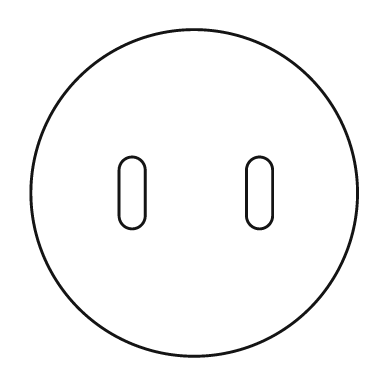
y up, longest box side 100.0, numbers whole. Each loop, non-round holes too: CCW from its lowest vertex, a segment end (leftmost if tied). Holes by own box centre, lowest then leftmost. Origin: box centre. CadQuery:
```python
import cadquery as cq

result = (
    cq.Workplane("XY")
    .moveTo(0.0, 0.0)
    .circle(50.0)
    .moveTo(-23.0, -7.0)
    .threePointArc((-19.0, -11.0), (-15.0, -7.0))
    .lineTo(-15.0, 7.0)
    .threePointArc((-19.0, 11.0), (-23.0, 7.0))
    .close()
    .moveTo(16.0, -7.0)
    .threePointArc((20.0, -11.0), (24.0, -7.0))
    .lineTo(24.0, 7.0)
    .threePointArc((20.0, 11.0), (16.0, 7.0))
    .close()
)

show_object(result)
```